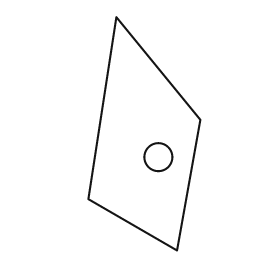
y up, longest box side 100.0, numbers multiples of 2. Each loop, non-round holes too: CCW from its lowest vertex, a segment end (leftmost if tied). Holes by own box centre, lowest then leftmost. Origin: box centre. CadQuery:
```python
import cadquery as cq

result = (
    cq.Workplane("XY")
    .moveTo(14.0, -50.0)
    .lineTo(24.0, 6.0)
    .lineTo(-12.0, 50.0)
    .lineTo(-24.0, -28.0)
    .close()
    .moveTo(6.0, -10.0)
    .circle(6.0)
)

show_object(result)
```